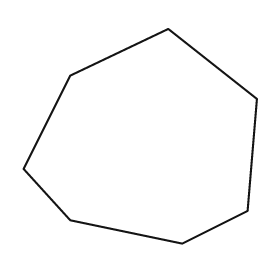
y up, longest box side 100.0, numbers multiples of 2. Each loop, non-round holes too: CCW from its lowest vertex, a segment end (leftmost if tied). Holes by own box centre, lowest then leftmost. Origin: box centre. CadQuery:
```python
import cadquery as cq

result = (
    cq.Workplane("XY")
    .moveTo(18.0, -46.0)
    .lineTo(46.0, -32.0)
    .lineTo(50.0, 16.0)
    .lineTo(12.0, 46.0)
    .lineTo(-30.0, 26.0)
    .lineTo(-50.0, -14.0)
    .lineTo(-30.0, -36.0)
    .close()
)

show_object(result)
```